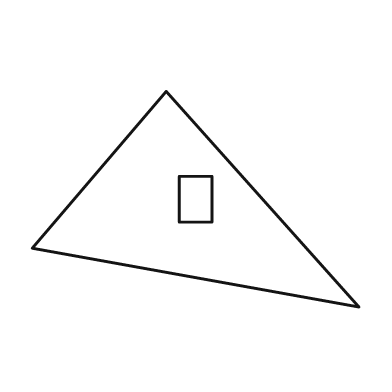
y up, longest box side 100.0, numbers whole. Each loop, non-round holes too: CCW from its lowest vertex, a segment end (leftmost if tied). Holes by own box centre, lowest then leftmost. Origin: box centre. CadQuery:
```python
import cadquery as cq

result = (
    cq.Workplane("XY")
    .moveTo(50.0, -33.0)
    .lineTo(-9.0, 33.0)
    .lineTo(-50.0, -15.0)
    .close()
    .moveTo(-5.0, -7.0)
    .lineTo(5.0, -7.0)
    .lineTo(5.0, 7.0)
    .lineTo(-5.0, 7.0)
    .close()
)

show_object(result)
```